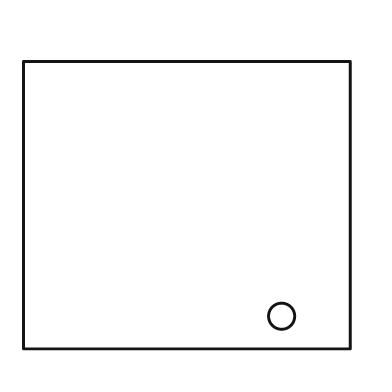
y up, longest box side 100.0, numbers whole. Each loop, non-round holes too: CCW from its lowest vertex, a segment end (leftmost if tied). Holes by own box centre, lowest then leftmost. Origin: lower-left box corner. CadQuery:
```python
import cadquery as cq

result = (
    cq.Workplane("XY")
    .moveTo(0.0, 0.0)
    .lineTo(100.0, 0.0)
    .lineTo(100.0, 88.0)
    .lineTo(0.0, 88.0)
    .close()
    .moveTo(79.0, 10.0)
    .circle(4.0)
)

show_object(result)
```